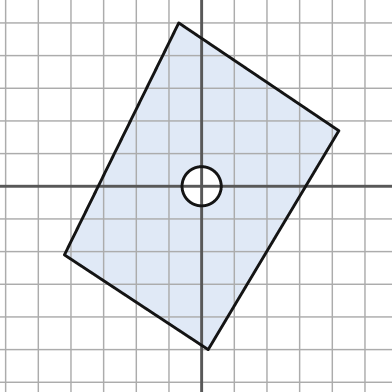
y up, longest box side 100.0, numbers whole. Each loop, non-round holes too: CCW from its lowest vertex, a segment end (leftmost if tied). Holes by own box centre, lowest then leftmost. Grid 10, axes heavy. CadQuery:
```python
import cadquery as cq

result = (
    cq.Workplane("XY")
    .moveTo(2.0, -50.0)
    .lineTo(42.0, 17.0)
    .lineTo(-7.0, 50.0)
    .lineTo(-42.0, -21.0)
    .close()
    .moveTo(0.0, 0.0)
    .circle(6.0)
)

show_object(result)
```